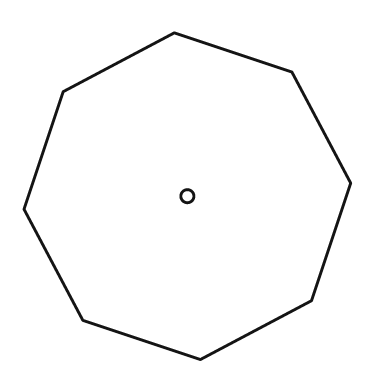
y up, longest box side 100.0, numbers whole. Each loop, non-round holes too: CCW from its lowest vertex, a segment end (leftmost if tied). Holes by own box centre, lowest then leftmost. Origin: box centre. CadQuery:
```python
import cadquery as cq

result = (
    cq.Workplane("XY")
    .moveTo(4.0, -50.0)
    .lineTo(38.0, -32.0)
    .lineTo(50.0, 4.0)
    .lineTo(32.0, 38.0)
    .lineTo(-4.0, 50.0)
    .lineTo(-38.0, 32.0)
    .lineTo(-50.0, -4.0)
    .lineTo(-32.0, -38.0)
    .close()
    .moveTo(0.0, 0.0)
    .circle(2.0)
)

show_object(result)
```